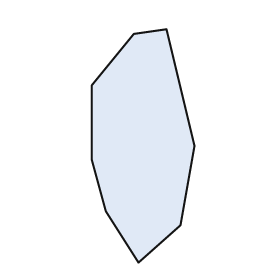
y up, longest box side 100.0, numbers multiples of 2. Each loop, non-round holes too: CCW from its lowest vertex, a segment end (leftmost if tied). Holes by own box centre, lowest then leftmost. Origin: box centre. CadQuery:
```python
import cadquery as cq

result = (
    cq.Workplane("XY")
    .moveTo(-2.0, -50.0)
    .lineTo(16.0, -34.0)
    .lineTo(22.0, 0.0)
    .lineTo(10.0, 50.0)
    .lineTo(-4.0, 48.0)
    .lineTo(-22.0, 26.0)
    .lineTo(-22.0, -6.0)
    .lineTo(-16.0, -28.0)
    .close()
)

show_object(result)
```